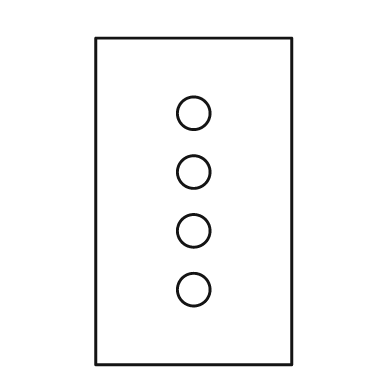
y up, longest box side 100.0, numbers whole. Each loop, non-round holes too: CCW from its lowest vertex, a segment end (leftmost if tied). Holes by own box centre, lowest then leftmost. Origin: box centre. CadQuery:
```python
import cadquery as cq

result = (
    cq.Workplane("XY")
    .moveTo(-30.0, -50.0)
    .lineTo(30.0, -50.0)
    .lineTo(30.0, 50.0)
    .lineTo(-30.0, 50.0)
    .close()
    .moveTo(0.0, -27.0)
    .circle(5.0)
    .moveTo(0.0, -9.0)
    .circle(5.0)
    .moveTo(0.0, 9.0)
    .circle(5.0)
    .moveTo(0.0, 27.0)
    .circle(5.0)
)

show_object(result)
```